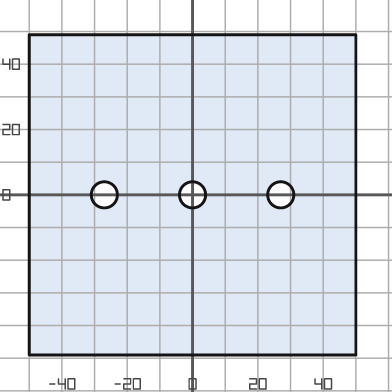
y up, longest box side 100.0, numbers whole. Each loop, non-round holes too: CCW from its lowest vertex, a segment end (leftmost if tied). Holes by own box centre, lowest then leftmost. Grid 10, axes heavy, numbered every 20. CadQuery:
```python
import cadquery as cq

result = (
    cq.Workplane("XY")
    .moveTo(-50.0, -49.0)
    .lineTo(50.0, -49.0)
    .lineTo(50.0, 49.0)
    .lineTo(-50.0, 49.0)
    .close()
    .moveTo(-27.0, 0.0)
    .circle(4.0)
    .moveTo(0.0, 0.0)
    .circle(4.0)
    .moveTo(27.0, 0.0)
    .circle(4.0)
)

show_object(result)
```